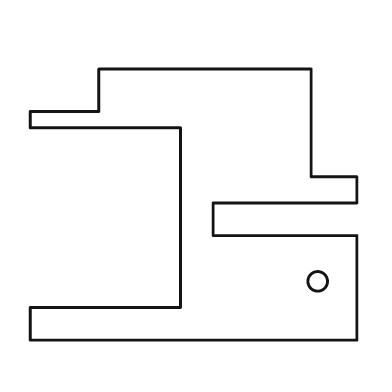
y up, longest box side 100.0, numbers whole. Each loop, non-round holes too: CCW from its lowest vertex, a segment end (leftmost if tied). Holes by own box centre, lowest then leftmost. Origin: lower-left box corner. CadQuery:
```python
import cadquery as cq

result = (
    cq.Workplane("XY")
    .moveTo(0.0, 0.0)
    .lineTo(100.0, 0.0)
    .lineTo(100.0, 32.0)
    .lineTo(56.0, 32.0)
    .lineTo(56.0, 42.0)
    .lineTo(100.0, 42.0)
    .lineTo(100.0, 50.0)
    .lineTo(86.0, 50.0)
    .lineTo(86.0, 83.0)
    .lineTo(21.0, 83.0)
    .lineTo(21.0, 70.0)
    .lineTo(0.0, 70.0)
    .lineTo(0.0, 65.0)
    .lineTo(46.0, 65.0)
    .lineTo(46.0, 10.0)
    .lineTo(0.0, 10.0)
    .close()
    .moveTo(88.0, 18.0)
    .circle(3.0)
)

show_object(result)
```